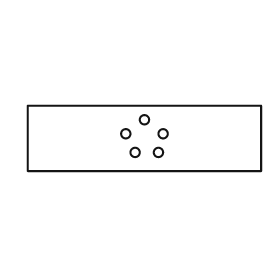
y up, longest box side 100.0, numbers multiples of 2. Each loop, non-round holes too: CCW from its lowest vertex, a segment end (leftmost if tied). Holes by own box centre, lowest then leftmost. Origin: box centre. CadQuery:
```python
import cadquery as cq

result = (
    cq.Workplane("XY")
    .moveTo(-50.0, -14.0)
    .lineTo(50.0, -14.0)
    .lineTo(50.0, 14.0)
    .lineTo(-50.0, 14.0)
    .close()
    .moveTo(-4.0, -6.0)
    .circle(2.0)
    .moveTo(6.0, -6.0)
    .circle(2.0)
    .moveTo(-8.0, 2.0)
    .circle(2.0)
    .moveTo(8.0, 2.0)
    .circle(2.0)
    .moveTo(0.0, 8.0)
    .circle(2.0)
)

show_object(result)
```